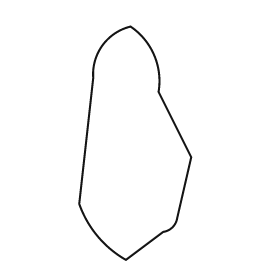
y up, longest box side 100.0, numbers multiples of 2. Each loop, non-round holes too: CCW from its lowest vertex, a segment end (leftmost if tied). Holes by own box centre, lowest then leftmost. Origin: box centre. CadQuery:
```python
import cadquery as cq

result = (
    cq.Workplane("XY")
    .moveTo(-4.0, -50.0)
    .lineTo(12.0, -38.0)
    .threePointArc((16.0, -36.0), (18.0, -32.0))
    .lineTo(24.0, -6.0)
    .lineTo(10.0, 22.0)
    .threePointArc((8.0, 38.0), (-2.0, 50.0))
    .threePointArc((-14.0, 42.0), (-18.0, 28.0))
    .lineTo(-24.0, -26.0)
    .threePointArc((-16.0, -40.0), (-4.0, -50.0))
    .close()
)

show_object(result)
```